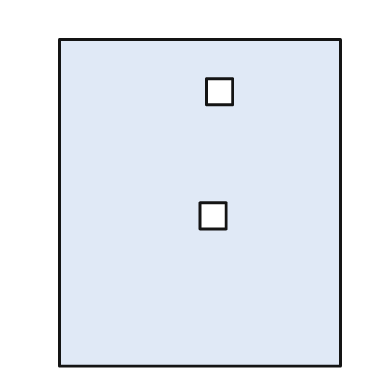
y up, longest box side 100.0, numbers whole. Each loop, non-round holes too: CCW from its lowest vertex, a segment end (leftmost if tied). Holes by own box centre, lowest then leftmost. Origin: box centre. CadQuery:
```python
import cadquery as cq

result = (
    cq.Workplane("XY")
    .moveTo(-43.0, -50.0)
    .lineTo(43.0, -50.0)
    .lineTo(43.0, 50.0)
    .lineTo(-43.0, 50.0)
    .close()
    .moveTo(0.0, -8.0)
    .lineTo(8.0, -8.0)
    .lineTo(8.0, 0.0)
    .lineTo(0.0, 0.0)
    .close()
    .moveTo(2.0, 30.0)
    .lineTo(10.0, 30.0)
    .lineTo(10.0, 38.0)
    .lineTo(2.0, 38.0)
    .close()
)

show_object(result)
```